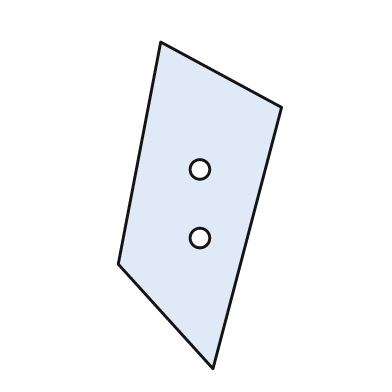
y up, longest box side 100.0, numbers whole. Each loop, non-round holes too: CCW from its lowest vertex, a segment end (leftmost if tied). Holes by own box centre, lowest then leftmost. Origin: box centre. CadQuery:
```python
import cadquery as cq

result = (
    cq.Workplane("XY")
    .moveTo(4.0, -50.0)
    .lineTo(25.0, 30.0)
    .lineTo(-12.0, 50.0)
    .lineTo(-25.0, -18.0)
    .close()
    .moveTo(0.0, -10.0)
    .circle(3.0)
    .moveTo(0.0, 11.0)
    .circle(3.0)
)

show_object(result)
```